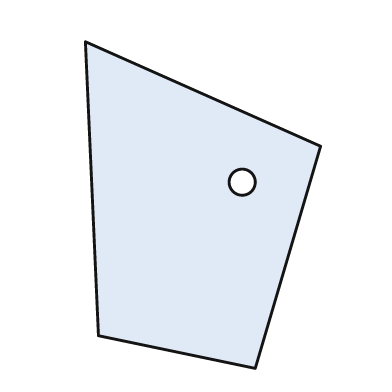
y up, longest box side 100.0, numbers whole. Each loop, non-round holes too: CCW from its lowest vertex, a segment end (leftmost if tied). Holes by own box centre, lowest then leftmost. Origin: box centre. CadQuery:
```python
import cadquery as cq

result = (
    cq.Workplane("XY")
    .moveTo(16.0, -50.0)
    .lineTo(36.0, 18.0)
    .lineTo(-36.0, 50.0)
    .lineTo(-32.0, -40.0)
    .close()
    .moveTo(12.0, 7.0)
    .circle(4.0)
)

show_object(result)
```